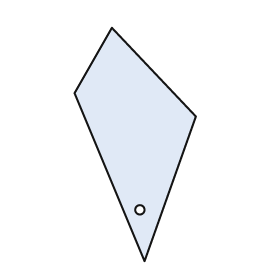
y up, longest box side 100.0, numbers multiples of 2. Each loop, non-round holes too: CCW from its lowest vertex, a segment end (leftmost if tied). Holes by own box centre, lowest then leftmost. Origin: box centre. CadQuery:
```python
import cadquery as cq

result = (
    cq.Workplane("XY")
    .moveTo(4.0, -50.0)
    .lineTo(26.0, 12.0)
    .lineTo(-10.0, 50.0)
    .lineTo(-26.0, 22.0)
    .close()
    .moveTo(2.0, -28.0)
    .circle(2.0)
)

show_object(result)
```